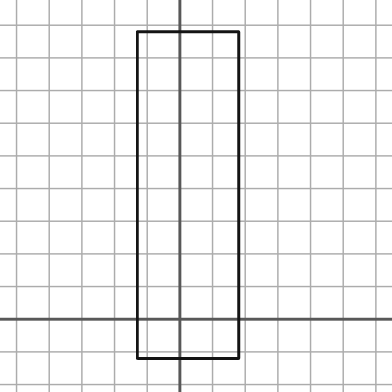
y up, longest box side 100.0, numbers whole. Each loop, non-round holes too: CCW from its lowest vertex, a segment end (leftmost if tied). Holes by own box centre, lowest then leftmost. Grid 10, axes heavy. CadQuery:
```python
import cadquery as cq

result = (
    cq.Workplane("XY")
    .moveTo(-13.0, -12.0)
    .lineTo(18.0, -12.0)
    .lineTo(18.0, 88.0)
    .lineTo(-13.0, 88.0)
    .close()
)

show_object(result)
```